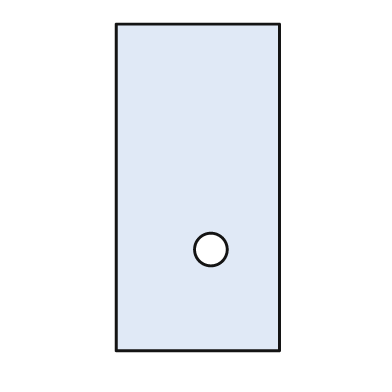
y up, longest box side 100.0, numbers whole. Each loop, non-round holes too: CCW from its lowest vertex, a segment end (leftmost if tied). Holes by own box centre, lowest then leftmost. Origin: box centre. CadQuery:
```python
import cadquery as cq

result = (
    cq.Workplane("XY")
    .moveTo(-25.0, -50.0)
    .lineTo(25.0, -50.0)
    .lineTo(25.0, 50.0)
    .lineTo(-25.0, 50.0)
    .close()
    .moveTo(4.0, -19.0)
    .circle(5.0)
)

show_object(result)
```